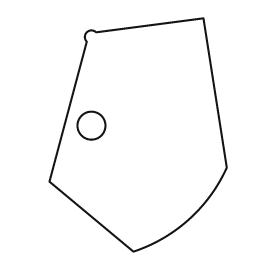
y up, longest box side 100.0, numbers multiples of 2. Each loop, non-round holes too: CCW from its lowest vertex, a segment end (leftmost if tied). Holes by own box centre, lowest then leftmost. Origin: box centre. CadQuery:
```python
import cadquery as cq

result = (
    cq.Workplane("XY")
    .moveTo(-2.0, -50.0)
    .threePointArc((22.0, -36.0), (38.0, -14.0))
    .lineTo(28.0, 50.0)
    .lineTo(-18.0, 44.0)
    .threePointArc((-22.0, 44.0), (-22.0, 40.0))
    .lineTo(-38.0, -20.0)
    .close()
    .moveTo(-20.0, 4.0)
    .circle(6.0)
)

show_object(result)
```